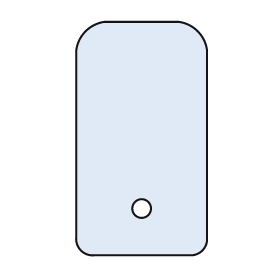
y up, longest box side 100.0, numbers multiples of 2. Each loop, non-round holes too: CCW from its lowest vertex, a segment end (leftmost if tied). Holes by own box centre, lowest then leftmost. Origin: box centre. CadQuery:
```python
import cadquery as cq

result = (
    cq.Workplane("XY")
    .moveTo(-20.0, -50.0)
    .lineTo(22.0, -50.0)
    .threePointArc((26.0, -48.0), (28.0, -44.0))
    .lineTo(28.0, 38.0)
    .threePointArc((24.0, 46.0), (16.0, 50.0))
    .lineTo(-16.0, 50.0)
    .threePointArc((-24.0, 46.0), (-28.0, 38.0))
    .lineTo(-28.0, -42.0)
    .threePointArc((-26.0, -48.0), (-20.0, -50.0))
    .close()
    .moveTo(0.0, -30.0)
    .circle(4.0)
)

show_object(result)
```